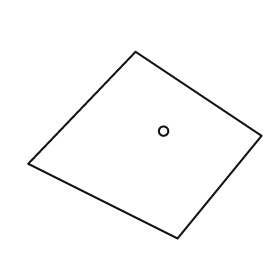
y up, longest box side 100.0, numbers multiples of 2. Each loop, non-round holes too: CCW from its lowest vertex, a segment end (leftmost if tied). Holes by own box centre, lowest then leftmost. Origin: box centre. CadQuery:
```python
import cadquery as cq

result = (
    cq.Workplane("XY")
    .moveTo(14.0, -40.0)
    .lineTo(50.0, 4.0)
    .lineTo(-4.0, 40.0)
    .lineTo(-50.0, -8.0)
    .close()
    .moveTo(8.0, 6.0)
    .circle(2.0)
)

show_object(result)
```